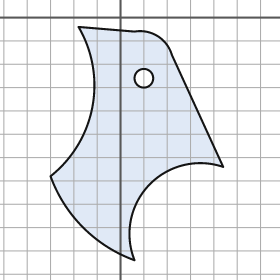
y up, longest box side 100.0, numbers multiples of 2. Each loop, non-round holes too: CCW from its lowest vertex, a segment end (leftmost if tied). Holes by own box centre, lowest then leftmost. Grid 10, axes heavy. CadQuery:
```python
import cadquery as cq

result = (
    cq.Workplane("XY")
    .moveTo(6.0, -104.0)
    .threePointArc((12.0, -72.0), (44.0, -64.0))
    .lineTo(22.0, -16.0)
    .threePointArc((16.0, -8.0), (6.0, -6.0))
    .lineTo(-18.0, -4.0)
    .threePointArc((-12.0, -38.0), (-30.0, -68.0))
    .threePointArc((-16.0, -90.0), (6.0, -104.0))
    .close()
    .moveTo(10.0, -26.0)
    .circle(4.0)
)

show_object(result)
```